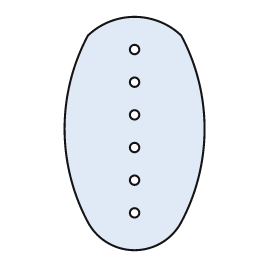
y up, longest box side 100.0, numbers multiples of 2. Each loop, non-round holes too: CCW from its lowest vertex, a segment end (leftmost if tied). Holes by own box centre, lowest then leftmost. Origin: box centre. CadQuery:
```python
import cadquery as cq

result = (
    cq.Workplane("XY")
    .moveTo(-20.0, -38.0)
    .threePointArc((0.0, -50.0), (20.0, -38.0))
    .threePointArc((30.0, 2.0), (20.0, 42.0))
    .threePointArc((0.0, 50.0), (-20.0, 42.0))
    .threePointArc((-30.0, 2.0), (-20.0, -38.0))
    .close()
    .moveTo(0.0, -34.0)
    .circle(2.0)
    .moveTo(0.0, -20.0)
    .circle(2.0)
    .moveTo(0.0, -6.0)
    .circle(2.0)
    .moveTo(0.0, 8.0)
    .circle(2.0)
    .moveTo(0.0, 22.0)
    .circle(2.0)
    .moveTo(0.0, 36.0)
    .circle(2.0)
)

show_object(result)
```